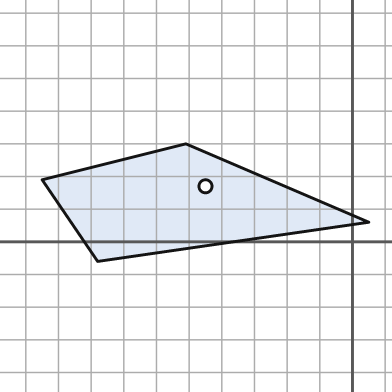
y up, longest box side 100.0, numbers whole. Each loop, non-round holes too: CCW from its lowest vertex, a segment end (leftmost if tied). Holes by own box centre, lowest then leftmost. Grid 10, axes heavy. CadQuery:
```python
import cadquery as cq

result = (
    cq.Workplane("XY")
    .moveTo(-78.0, -6.0)
    .lineTo(5.0, 6.0)
    .lineTo(-51.0, 30.0)
    .lineTo(-95.0, 19.0)
    .close()
    .moveTo(-45.0, 17.0)
    .circle(2.0)
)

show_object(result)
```